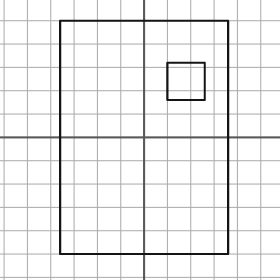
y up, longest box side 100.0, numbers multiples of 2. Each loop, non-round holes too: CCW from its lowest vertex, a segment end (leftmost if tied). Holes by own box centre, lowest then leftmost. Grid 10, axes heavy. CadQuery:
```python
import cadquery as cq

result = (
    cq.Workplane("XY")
    .moveTo(-36.0, -50.0)
    .lineTo(36.0, -50.0)
    .lineTo(36.0, 50.0)
    .lineTo(-36.0, 50.0)
    .close()
    .moveTo(10.0, 16.0)
    .lineTo(26.0, 16.0)
    .lineTo(26.0, 32.0)
    .lineTo(10.0, 32.0)
    .close()
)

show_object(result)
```